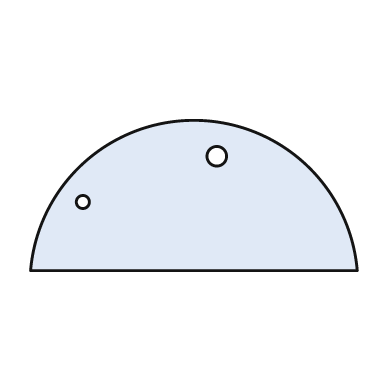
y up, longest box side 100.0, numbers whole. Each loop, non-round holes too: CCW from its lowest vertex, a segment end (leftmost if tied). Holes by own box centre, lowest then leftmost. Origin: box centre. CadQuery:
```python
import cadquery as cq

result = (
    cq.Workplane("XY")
    .moveTo(-50.0, -23.0)
    .lineTo(50.0, -23.0)
    .threePointArc((0.0, 23.0), (-50.0, -23.0))
    .close()
    .moveTo(-34.0, -2.0)
    .circle(2.0)
    .moveTo(7.0, 12.0)
    .circle(3.0)
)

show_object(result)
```